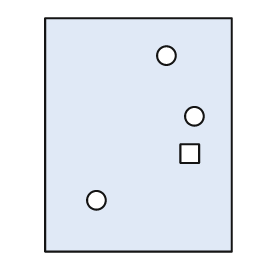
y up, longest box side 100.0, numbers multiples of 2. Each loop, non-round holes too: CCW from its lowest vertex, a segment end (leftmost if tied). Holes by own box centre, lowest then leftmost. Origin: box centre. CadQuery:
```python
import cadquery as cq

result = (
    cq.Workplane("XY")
    .moveTo(-40.0, -50.0)
    .lineTo(40.0, -50.0)
    .lineTo(40.0, 50.0)
    .lineTo(-40.0, 50.0)
    .close()
    .moveTo(-18.0, -28.0)
    .circle(4.0)
    .moveTo(18.0, -12.0)
    .lineTo(26.0, -12.0)
    .lineTo(26.0, -4.0)
    .lineTo(18.0, -4.0)
    .close()
    .moveTo(24.0, 8.0)
    .circle(4.0)
    .moveTo(12.0, 34.0)
    .circle(4.0)
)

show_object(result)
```